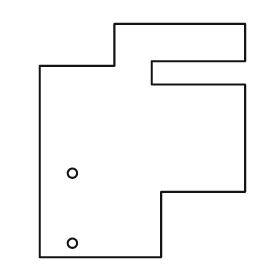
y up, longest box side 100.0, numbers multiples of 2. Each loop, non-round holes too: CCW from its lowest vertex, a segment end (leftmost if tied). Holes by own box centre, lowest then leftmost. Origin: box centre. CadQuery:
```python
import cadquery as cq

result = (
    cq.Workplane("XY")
    .moveTo(-44.0, -50.0)
    .lineTo(8.0, -50.0)
    .lineTo(8.0, -22.0)
    .lineTo(44.0, -22.0)
    .lineTo(44.0, 24.0)
    .lineTo(4.0, 24.0)
    .lineTo(4.0, 34.0)
    .lineTo(44.0, 34.0)
    .lineTo(44.0, 50.0)
    .lineTo(-12.0, 50.0)
    .lineTo(-12.0, 32.0)
    .lineTo(-44.0, 32.0)
    .close()
    .moveTo(-30.0, -44.0)
    .circle(2.0)
    .moveTo(-30.0, -14.0)
    .circle(2.0)
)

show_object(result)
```